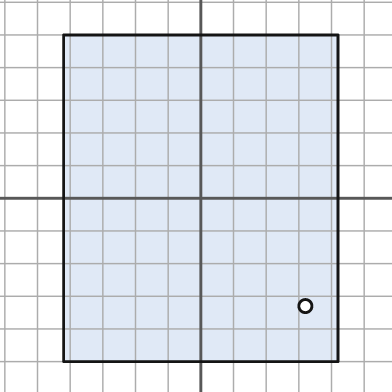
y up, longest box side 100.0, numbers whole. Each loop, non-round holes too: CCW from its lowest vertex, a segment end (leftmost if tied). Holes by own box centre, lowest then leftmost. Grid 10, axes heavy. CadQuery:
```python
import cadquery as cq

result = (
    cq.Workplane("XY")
    .moveTo(-42.0, -50.0)
    .lineTo(42.0, -50.0)
    .lineTo(42.0, 50.0)
    .lineTo(-42.0, 50.0)
    .close()
    .moveTo(32.0, -33.0)
    .circle(2.0)
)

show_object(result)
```